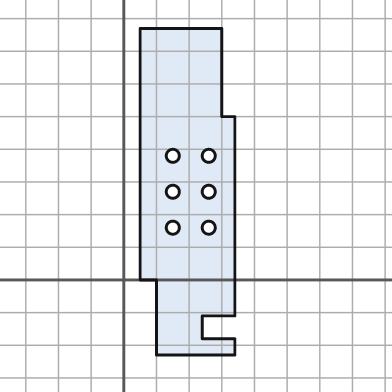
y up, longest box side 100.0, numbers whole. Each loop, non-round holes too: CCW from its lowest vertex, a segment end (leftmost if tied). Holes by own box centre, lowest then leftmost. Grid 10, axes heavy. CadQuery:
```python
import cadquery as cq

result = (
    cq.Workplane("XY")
    .moveTo(10.0, -23.0)
    .lineTo(34.0, -23.0)
    .lineTo(34.0, -18.0)
    .lineTo(24.0, -18.0)
    .lineTo(24.0, -11.0)
    .lineTo(34.0, -11.0)
    .lineTo(34.0, 50.0)
    .lineTo(30.0, 50.0)
    .lineTo(30.0, 77.0)
    .lineTo(5.0, 77.0)
    .lineTo(5.0, 0.0)
    .lineTo(10.0, 0.0)
    .close()
    .moveTo(15.0, 16.0)
    .circle(2.0)
    .moveTo(26.0, 16.0)
    .circle(2.0)
    .moveTo(15.0, 27.0)
    .circle(2.0)
    .moveTo(26.0, 27.0)
    .circle(2.0)
    .moveTo(15.0, 38.0)
    .circle(2.0)
    .moveTo(26.0, 38.0)
    .circle(2.0)
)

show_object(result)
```